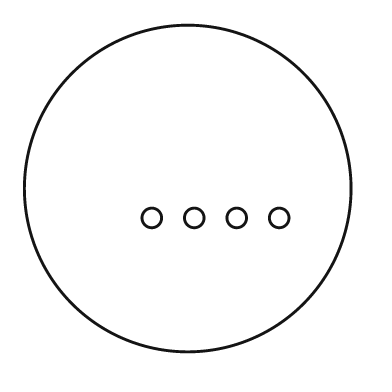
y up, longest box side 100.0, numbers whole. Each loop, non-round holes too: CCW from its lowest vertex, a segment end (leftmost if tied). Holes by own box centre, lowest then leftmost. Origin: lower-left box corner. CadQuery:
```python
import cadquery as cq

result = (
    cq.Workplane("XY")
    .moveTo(50.0, 50.0)
    .circle(50.0)
    .moveTo(39.0, 41.0)
    .circle(3.0)
    .moveTo(52.0, 41.0)
    .circle(3.0)
    .moveTo(65.0, 41.0)
    .circle(3.0)
    .moveTo(78.0, 41.0)
    .circle(3.0)
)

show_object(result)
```